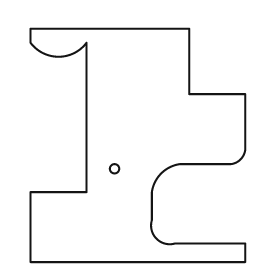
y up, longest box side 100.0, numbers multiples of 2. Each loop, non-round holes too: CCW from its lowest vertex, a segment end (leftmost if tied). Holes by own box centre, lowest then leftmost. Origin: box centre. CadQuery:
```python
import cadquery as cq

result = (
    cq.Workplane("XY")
    .moveTo(-46.0, -50.0)
    .lineTo(46.0, -50.0)
    .lineTo(46.0, -42.0)
    .lineTo(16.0, -42.0)
    .threePointArc((8.0, -40.0), (6.0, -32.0))
    .lineTo(6.0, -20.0)
    .threePointArc((10.0, -12.0), (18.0, -8.0))
    .lineTo(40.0, -8.0)
    .threePointArc((44.0, -6.0), (46.0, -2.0))
    .lineTo(46.0, 22.0)
    .lineTo(22.0, 22.0)
    .lineTo(22.0, 50.0)
    .lineTo(-46.0, 50.0)
    .lineTo(-46.0, 44.0)
    .threePointArc((-34.0, 38.0), (-22.0, 44.0))
    .lineTo(-22.0, -20.0)
    .lineTo(-46.0, -20.0)
    .close()
    .moveTo(-10.0, -10.0)
    .circle(2.0)
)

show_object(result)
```